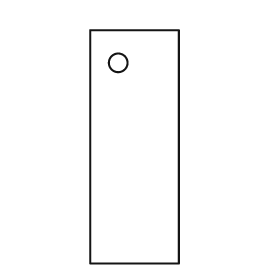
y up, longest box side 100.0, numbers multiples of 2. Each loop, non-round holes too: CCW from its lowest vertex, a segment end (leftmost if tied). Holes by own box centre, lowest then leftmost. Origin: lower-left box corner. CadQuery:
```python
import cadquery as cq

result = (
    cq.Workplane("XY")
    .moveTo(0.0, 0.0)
    .lineTo(38.0, 0.0)
    .lineTo(38.0, 100.0)
    .lineTo(0.0, 100.0)
    .close()
    .moveTo(12.0, 86.0)
    .circle(4.0)
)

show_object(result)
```